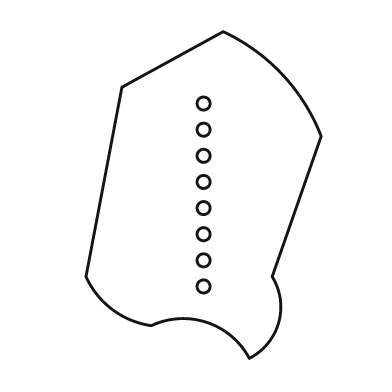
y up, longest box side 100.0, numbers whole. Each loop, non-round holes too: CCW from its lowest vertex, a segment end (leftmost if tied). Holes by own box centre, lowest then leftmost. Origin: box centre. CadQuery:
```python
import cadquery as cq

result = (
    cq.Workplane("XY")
    .moveTo(14.0, -50.0)
    .threePointArc((23.0, -39.0), (21.0, -25.0))
    .lineTo(36.0, 18.0)
    .threePointArc((24.0, 37.0), (6.0, 50.0))
    .lineTo(-25.0, 33.0)
    .lineTo(-36.0, -25.0)
    .threePointArc((-28.0, -35.0), (-16.0, -40.0))
    .threePointArc((1.0, -39.0), (14.0, -50.0))
    .close()
    .moveTo(0.0, -28.0)
    .circle(2.0)
    .moveTo(0.0, -20.0)
    .circle(2.0)
    .moveTo(0.0, -12.0)
    .circle(2.0)
    .moveTo(0.0, -4.0)
    .circle(2.0)
    .moveTo(0.0, 4.0)
    .circle(2.0)
    .moveTo(0.0, 12.0)
    .circle(2.0)
    .moveTo(0.0, 20.0)
    .circle(2.0)
    .moveTo(0.0, 28.0)
    .circle(2.0)
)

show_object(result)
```